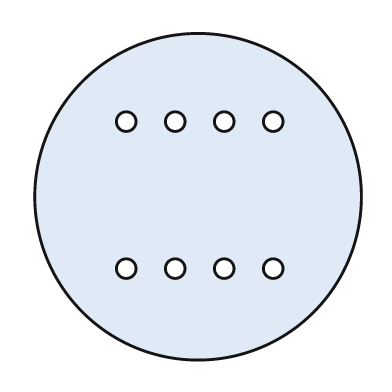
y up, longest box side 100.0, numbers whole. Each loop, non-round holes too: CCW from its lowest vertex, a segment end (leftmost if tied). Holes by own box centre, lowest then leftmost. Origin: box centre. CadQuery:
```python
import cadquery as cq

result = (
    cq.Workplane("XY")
    .moveTo(0.0, 0.0)
    .circle(50.0)
    .moveTo(-22.0, -22.0)
    .circle(3.0)
    .moveTo(-7.0, -22.0)
    .circle(3.0)
    .moveTo(8.0, -22.0)
    .circle(3.0)
    .moveTo(23.0, -22.0)
    .circle(3.0)
    .moveTo(-22.0, 23.0)
    .circle(3.0)
    .moveTo(-7.0, 23.0)
    .circle(3.0)
    .moveTo(8.0, 23.0)
    .circle(3.0)
    .moveTo(23.0, 23.0)
    .circle(3.0)
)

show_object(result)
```